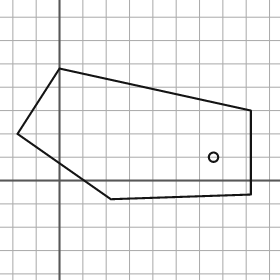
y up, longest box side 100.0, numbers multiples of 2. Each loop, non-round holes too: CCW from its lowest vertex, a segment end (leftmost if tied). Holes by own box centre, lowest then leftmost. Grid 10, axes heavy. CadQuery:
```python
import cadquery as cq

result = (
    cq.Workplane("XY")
    .moveTo(22.0, -8.0)
    .lineTo(82.0, -6.0)
    .lineTo(82.0, 30.0)
    .lineTo(0.0, 48.0)
    .lineTo(-18.0, 20.0)
    .close()
    .moveTo(66.0, 10.0)
    .circle(2.0)
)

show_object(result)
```